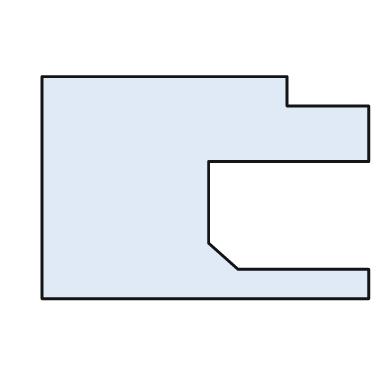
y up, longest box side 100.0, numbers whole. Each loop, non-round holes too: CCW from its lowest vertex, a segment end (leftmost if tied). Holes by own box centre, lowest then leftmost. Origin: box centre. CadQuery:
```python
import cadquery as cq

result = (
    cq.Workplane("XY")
    .moveTo(-50.0, -34.0)
    .lineTo(50.0, -34.0)
    .lineTo(50.0, -25.0)
    .lineTo(10.0, -25.0)
    .lineTo(1.0, -17.0)
    .lineTo(1.0, 8.0)
    .lineTo(50.0, 8.0)
    .lineTo(50.0, 25.0)
    .lineTo(25.0, 25.0)
    .lineTo(25.0, 34.0)
    .lineTo(-50.0, 34.0)
    .close()
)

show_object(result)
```